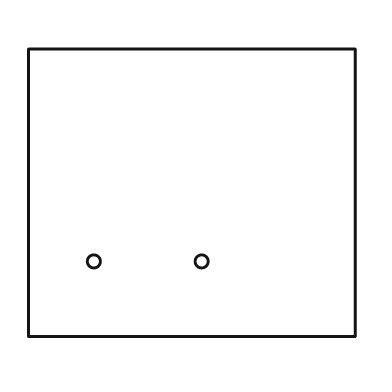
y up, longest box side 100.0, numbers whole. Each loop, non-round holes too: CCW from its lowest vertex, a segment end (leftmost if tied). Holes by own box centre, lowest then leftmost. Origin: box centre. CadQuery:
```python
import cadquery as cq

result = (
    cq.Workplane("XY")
    .moveTo(-50.0, -44.0)
    .lineTo(50.0, -44.0)
    .lineTo(50.0, 44.0)
    .lineTo(-50.0, 44.0)
    .close()
    .moveTo(-30.0, -21.0)
    .circle(2.0)
    .moveTo(3.0, -21.0)
    .circle(2.0)
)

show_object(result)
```